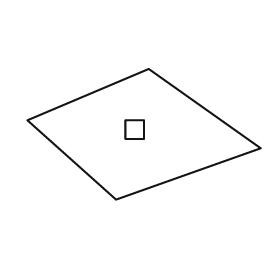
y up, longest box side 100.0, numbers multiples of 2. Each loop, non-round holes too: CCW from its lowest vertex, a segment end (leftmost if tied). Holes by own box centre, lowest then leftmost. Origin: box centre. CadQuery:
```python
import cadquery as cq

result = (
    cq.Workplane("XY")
    .moveTo(-12.0, -28.0)
    .lineTo(50.0, -6.0)
    .lineTo(2.0, 28.0)
    .lineTo(-50.0, 6.0)
    .close()
    .moveTo(-8.0, -2.0)
    .lineTo(0.0, -2.0)
    .lineTo(0.0, 6.0)
    .lineTo(-8.0, 6.0)
    .close()
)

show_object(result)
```